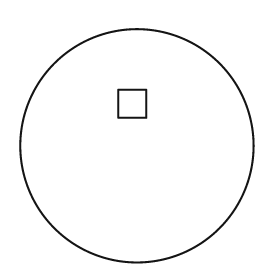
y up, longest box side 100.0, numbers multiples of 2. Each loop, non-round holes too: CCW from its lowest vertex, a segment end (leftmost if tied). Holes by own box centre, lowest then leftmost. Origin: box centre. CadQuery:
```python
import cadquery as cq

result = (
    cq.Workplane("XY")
    .moveTo(0.0, 0.0)
    .circle(50.0)
    .moveTo(-8.0, 12.0)
    .lineTo(4.0, 12.0)
    .lineTo(4.0, 24.0)
    .lineTo(-8.0, 24.0)
    .close()
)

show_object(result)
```